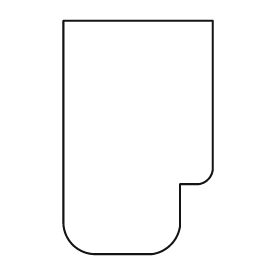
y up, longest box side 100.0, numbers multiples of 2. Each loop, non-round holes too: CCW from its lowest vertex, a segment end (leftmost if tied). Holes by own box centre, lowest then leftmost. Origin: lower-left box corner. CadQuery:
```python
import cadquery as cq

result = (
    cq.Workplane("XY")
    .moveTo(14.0, 0.0)
    .lineTo(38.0, 0.0)
    .threePointArc((46.0, 4.0), (50.0, 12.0))
    .lineTo(50.0, 30.0)
    .lineTo(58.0, 30.0)
    .threePointArc((62.0, 32.0), (64.0, 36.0))
    .lineTo(64.0, 100.0)
    .lineTo(0.0, 100.0)
    .lineTo(0.0, 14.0)
    .threePointArc((4.0, 4.0), (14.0, 0.0))
    .close()
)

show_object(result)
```